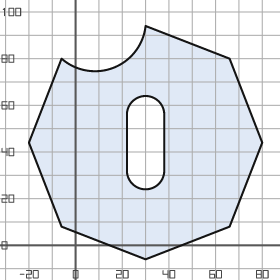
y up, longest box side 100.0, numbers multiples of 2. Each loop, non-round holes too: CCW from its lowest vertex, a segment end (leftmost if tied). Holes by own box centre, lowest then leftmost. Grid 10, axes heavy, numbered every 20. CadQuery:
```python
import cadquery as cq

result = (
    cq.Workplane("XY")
    .moveTo(30.0, -6.0)
    .lineTo(66.0, 8.0)
    .lineTo(80.0, 44.0)
    .lineTo(66.0, 80.0)
    .lineTo(30.0, 94.0)
    .threePointArc((16.0, 76.0), (-6.0, 80.0))
    .lineTo(-20.0, 44.0)
    .lineTo(-6.0, 8.0)
    .close()
    .moveTo(22.0, 32.0)
    .threePointArc((30.0, 24.0), (38.0, 32.0))
    .lineTo(38.0, 56.0)
    .threePointArc((30.0, 64.0), (22.0, 56.0))
    .close()
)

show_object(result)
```